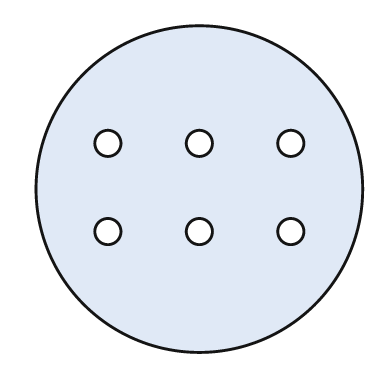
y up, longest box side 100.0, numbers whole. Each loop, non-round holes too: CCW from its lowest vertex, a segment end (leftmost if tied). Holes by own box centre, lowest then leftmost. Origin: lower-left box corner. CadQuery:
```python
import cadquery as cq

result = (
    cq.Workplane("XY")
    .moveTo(50.0, 50.0)
    .circle(50.0)
    .moveTo(22.0, 37.0)
    .circle(4.0)
    .moveTo(50.0, 37.0)
    .circle(4.0)
    .moveTo(78.0, 37.0)
    .circle(4.0)
    .moveTo(22.0, 64.0)
    .circle(4.0)
    .moveTo(50.0, 64.0)
    .circle(4.0)
    .moveTo(78.0, 64.0)
    .circle(4.0)
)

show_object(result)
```